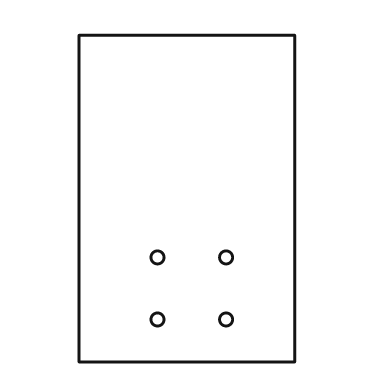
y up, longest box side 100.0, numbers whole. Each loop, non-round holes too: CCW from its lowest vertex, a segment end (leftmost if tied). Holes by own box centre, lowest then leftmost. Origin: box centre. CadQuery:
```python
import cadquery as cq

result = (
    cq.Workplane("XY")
    .moveTo(-33.0, -50.0)
    .lineTo(33.0, -50.0)
    .lineTo(33.0, 50.0)
    .lineTo(-33.0, 50.0)
    .close()
    .moveTo(-9.0, -37.0)
    .circle(2.0)
    .moveTo(12.0, -37.0)
    .circle(2.0)
    .moveTo(-9.0, -18.0)
    .circle(2.0)
    .moveTo(12.0, -18.0)
    .circle(2.0)
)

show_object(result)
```